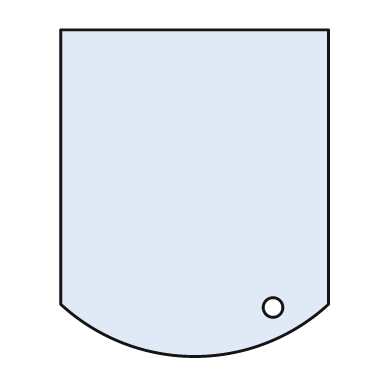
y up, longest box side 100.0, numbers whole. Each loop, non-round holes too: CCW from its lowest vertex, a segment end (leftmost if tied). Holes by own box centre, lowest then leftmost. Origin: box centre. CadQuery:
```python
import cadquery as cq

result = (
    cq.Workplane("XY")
    .moveTo(-41.0, -34.0)
    .threePointArc((0.0, -50.0), (41.0, -34.0))
    .lineTo(41.0, 50.0)
    .lineTo(-41.0, 50.0)
    .close()
    .moveTo(24.0, -35.0)
    .circle(3.0)
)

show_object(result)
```